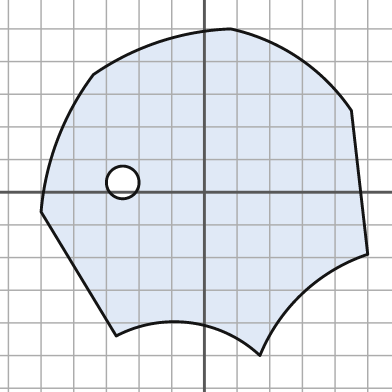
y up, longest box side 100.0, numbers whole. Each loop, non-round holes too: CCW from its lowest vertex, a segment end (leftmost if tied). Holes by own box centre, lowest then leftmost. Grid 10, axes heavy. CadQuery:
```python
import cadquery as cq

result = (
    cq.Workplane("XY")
    .moveTo(17.0, -50.0)
    .threePointArc((30.0, -31.0), (50.0, -19.0))
    .lineTo(45.0, 25.0)
    .threePointArc((29.0, 41.0), (8.0, 50.0))
    .threePointArc((-14.0, 46.0), (-34.0, 36.0))
    .threePointArc((-45.0, 16.0), (-50.0, -6.0))
    .lineTo(-27.0, -44.0)
    .threePointArc((-4.0, -40.0), (17.0, -50.0))
    .close()
    .moveTo(-25.0, 3.0)
    .circle(5.0)
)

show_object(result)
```